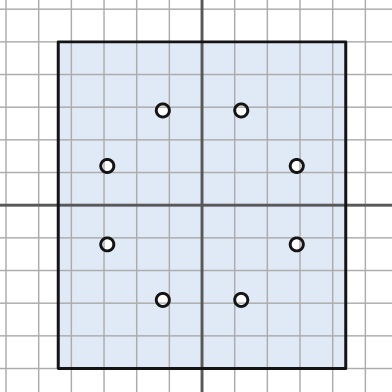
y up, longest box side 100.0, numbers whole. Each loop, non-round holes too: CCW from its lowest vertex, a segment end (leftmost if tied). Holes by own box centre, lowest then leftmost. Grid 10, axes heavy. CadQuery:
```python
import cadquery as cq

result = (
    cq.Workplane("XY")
    .moveTo(-44.0, -50.0)
    .lineTo(44.0, -50.0)
    .lineTo(44.0, 50.0)
    .lineTo(-44.0, 50.0)
    .close()
    .moveTo(-12.0, -29.0)
    .circle(2.0)
    .moveTo(12.0, -29.0)
    .circle(2.0)
    .moveTo(-29.0, -12.0)
    .circle(2.0)
    .moveTo(29.0, -12.0)
    .circle(2.0)
    .moveTo(-29.0, 12.0)
    .circle(2.0)
    .moveTo(29.0, 12.0)
    .circle(2.0)
    .moveTo(-12.0, 29.0)
    .circle(2.0)
    .moveTo(12.0, 29.0)
    .circle(2.0)
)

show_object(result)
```